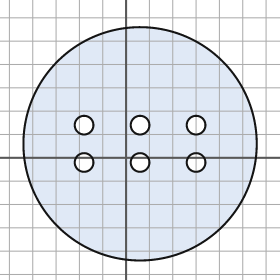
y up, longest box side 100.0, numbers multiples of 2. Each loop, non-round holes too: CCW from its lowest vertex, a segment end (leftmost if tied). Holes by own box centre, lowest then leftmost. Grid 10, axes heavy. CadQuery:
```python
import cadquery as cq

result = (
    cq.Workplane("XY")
    .moveTo(6.0, 6.0)
    .circle(50.0)
    .moveTo(-18.0, -2.0)
    .circle(4.0)
    .moveTo(6.0, -2.0)
    .circle(4.0)
    .moveTo(30.0, -2.0)
    .circle(4.0)
    .moveTo(-18.0, 14.0)
    .circle(4.0)
    .moveTo(6.0, 14.0)
    .circle(4.0)
    .moveTo(30.0, 14.0)
    .circle(4.0)
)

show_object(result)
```